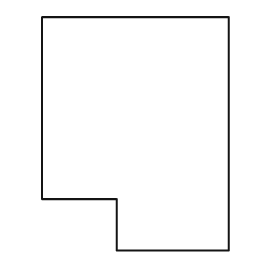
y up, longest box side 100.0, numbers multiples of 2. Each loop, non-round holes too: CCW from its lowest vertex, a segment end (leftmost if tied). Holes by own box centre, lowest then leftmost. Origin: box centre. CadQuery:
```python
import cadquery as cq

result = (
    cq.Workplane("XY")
    .moveTo(-8.0, -50.0)
    .lineTo(40.0, -50.0)
    .lineTo(40.0, 50.0)
    .lineTo(-40.0, 50.0)
    .lineTo(-40.0, -28.0)
    .lineTo(-8.0, -28.0)
    .close()
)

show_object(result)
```